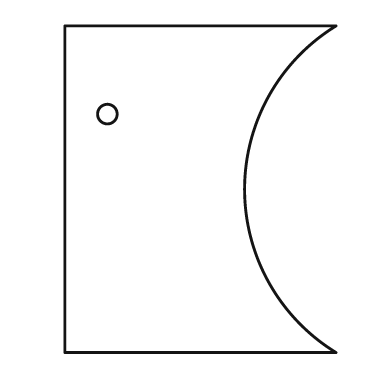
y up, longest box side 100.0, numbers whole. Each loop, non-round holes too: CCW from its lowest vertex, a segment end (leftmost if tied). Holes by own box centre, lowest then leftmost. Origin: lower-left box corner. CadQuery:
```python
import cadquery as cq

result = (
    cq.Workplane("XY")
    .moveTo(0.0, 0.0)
    .lineTo(83.0, 0.0)
    .threePointArc((55.0, 50.0), (83.0, 100.0))
    .lineTo(0.0, 100.0)
    .close()
    .moveTo(13.0, 73.0)
    .circle(3.0)
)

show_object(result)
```